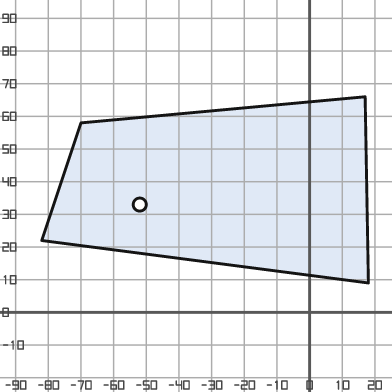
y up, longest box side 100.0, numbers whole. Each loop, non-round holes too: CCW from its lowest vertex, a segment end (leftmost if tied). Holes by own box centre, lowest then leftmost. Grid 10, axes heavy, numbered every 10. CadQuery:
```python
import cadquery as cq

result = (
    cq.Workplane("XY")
    .moveTo(18.0, 9.0)
    .lineTo(17.0, 66.0)
    .lineTo(-70.0, 58.0)
    .lineTo(-82.0, 22.0)
    .close()
    .moveTo(-52.0, 33.0)
    .circle(2.0)
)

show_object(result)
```